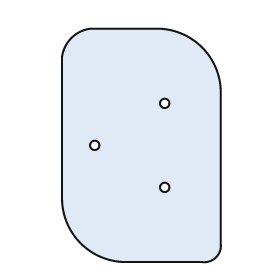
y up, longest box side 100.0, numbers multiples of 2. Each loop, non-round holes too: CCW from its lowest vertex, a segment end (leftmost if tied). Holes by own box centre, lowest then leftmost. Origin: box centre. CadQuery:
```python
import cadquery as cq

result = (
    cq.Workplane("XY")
    .moveTo(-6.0, -50.0)
    .lineTo(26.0, -50.0)
    .threePointArc((32.0, -48.0), (34.0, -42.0))
    .lineTo(34.0, 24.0)
    .threePointArc((26.0, 42.0), (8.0, 50.0))
    .lineTo(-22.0, 50.0)
    .threePointArc((-30.0, 46.0), (-34.0, 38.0))
    .lineTo(-34.0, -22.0)
    .threePointArc((-26.0, -42.0), (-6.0, -50.0))
    .close()
    .moveTo(10.0, -18.0)
    .circle(2.0)
    .moveTo(-20.0, 0.0)
    .circle(2.0)
    .moveTo(10.0, 18.0)
    .circle(2.0)
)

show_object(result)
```